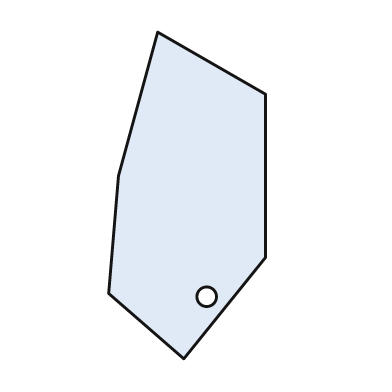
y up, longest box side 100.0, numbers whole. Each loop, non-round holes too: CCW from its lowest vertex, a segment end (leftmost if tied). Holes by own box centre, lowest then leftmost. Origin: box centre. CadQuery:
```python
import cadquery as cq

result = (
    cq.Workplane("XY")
    .moveTo(-1.0, -50.0)
    .lineTo(24.0, -19.0)
    .lineTo(24.0, 31.0)
    .lineTo(-9.0, 50.0)
    .lineTo(-21.0, 6.0)
    .lineTo(-24.0, -30.0)
    .close()
    .moveTo(6.0, -31.0)
    .circle(3.0)
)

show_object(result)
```